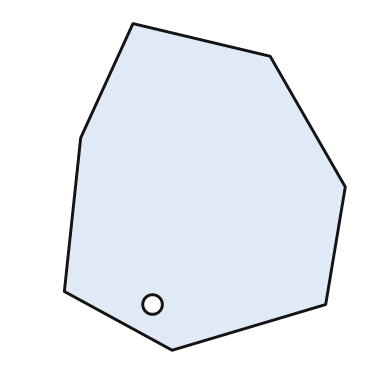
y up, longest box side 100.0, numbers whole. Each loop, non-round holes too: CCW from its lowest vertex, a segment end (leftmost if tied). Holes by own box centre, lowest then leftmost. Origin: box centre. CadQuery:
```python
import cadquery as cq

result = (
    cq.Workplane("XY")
    .moveTo(-10.0, -50.0)
    .lineTo(37.0, -36.0)
    .lineTo(43.0, 0.0)
    .lineTo(20.0, 40.0)
    .lineTo(-22.0, 50.0)
    .lineTo(-38.0, 15.0)
    .lineTo(-43.0, -32.0)
    .close()
    .moveTo(-16.0, -36.0)
    .circle(3.0)
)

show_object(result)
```